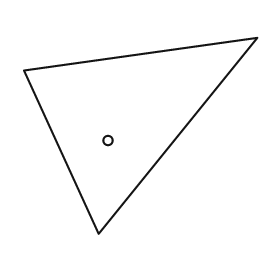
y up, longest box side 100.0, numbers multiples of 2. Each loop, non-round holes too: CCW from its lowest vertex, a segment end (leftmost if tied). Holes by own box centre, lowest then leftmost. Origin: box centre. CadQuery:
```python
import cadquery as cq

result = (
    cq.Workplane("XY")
    .moveTo(-18.0, -42.0)
    .lineTo(50.0, 42.0)
    .lineTo(-50.0, 28.0)
    .close()
    .moveTo(-14.0, -2.0)
    .circle(2.0)
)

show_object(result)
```